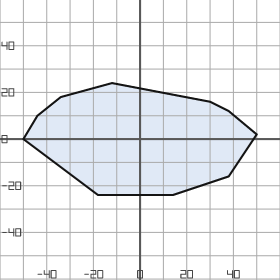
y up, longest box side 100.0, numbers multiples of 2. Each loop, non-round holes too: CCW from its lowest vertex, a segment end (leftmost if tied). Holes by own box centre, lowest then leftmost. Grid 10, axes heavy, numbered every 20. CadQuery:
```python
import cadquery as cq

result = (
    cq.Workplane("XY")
    .moveTo(-18.0, -24.0)
    .lineTo(14.0, -24.0)
    .lineTo(38.0, -16.0)
    .lineTo(50.0, 2.0)
    .lineTo(38.0, 12.0)
    .lineTo(30.0, 16.0)
    .lineTo(-12.0, 24.0)
    .lineTo(-34.0, 18.0)
    .lineTo(-44.0, 10.0)
    .lineTo(-50.0, 0.0)
    .close()
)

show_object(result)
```